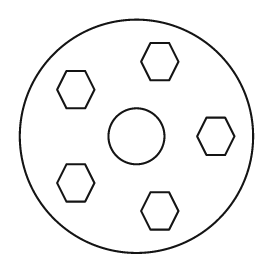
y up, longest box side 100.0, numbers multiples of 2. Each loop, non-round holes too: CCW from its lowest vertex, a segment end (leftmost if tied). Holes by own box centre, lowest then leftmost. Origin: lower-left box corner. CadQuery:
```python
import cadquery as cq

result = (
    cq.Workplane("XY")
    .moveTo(50.0, 50.0)
    .circle(50.0)
    .moveTo(56.0, 10.0)
    .lineTo(64.0, 10.0)
    .lineTo(68.0, 18.0)
    .lineTo(64.0, 26.0)
    .lineTo(56.0, 26.0)
    .lineTo(52.0, 18.0)
    .close()
    .moveTo(20.0, 22.0)
    .lineTo(28.0, 22.0)
    .lineTo(32.0, 30.0)
    .lineTo(28.0, 38.0)
    .lineTo(20.0, 38.0)
    .lineTo(16.0, 30.0)
    .close()
    .moveTo(50.0, 50.0)
    .circle(12.0)
    .moveTo(80.0, 42.0)
    .lineTo(88.0, 42.0)
    .lineTo(92.0, 50.0)
    .lineTo(88.0, 58.0)
    .lineTo(80.0, 58.0)
    .lineTo(76.0, 50.0)
    .close()
    .moveTo(20.0, 62.0)
    .lineTo(28.0, 62.0)
    .lineTo(32.0, 70.0)
    .lineTo(28.0, 78.0)
    .lineTo(20.0, 78.0)
    .lineTo(16.0, 70.0)
    .close()
    .moveTo(56.0, 74.0)
    .lineTo(64.0, 74.0)
    .lineTo(68.0, 82.0)
    .lineTo(64.0, 90.0)
    .lineTo(56.0, 90.0)
    .lineTo(52.0, 82.0)
    .close()
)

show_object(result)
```